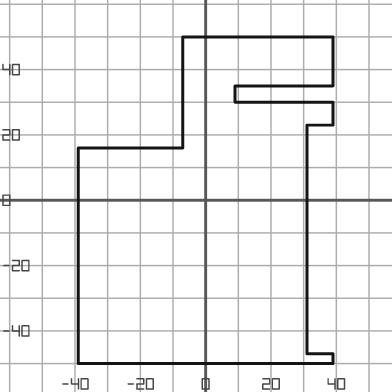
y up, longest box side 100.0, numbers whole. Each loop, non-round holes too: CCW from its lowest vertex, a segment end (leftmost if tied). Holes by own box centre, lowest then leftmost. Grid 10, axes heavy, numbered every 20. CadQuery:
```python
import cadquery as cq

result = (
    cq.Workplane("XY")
    .moveTo(-39.0, -50.0)
    .lineTo(39.0, -50.0)
    .lineTo(39.0, -47.0)
    .lineTo(31.0, -47.0)
    .lineTo(31.0, 23.0)
    .lineTo(39.0, 23.0)
    .lineTo(39.0, 30.0)
    .lineTo(9.0, 30.0)
    .lineTo(9.0, 35.0)
    .lineTo(39.0, 35.0)
    .lineTo(39.0, 50.0)
    .lineTo(-7.0, 50.0)
    .lineTo(-7.0, 16.0)
    .lineTo(-39.0, 16.0)
    .close()
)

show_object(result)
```